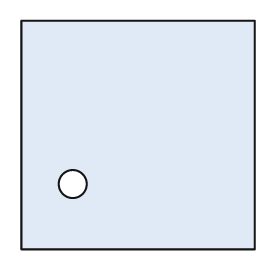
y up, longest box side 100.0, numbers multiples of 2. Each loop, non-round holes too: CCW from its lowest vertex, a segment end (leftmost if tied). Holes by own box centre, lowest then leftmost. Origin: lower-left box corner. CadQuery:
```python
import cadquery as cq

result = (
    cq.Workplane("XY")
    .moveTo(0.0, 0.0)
    .lineTo(100.0, 0.0)
    .lineTo(100.0, 98.0)
    .lineTo(0.0, 98.0)
    .close()
    .moveTo(22.0, 28.0)
    .circle(6.0)
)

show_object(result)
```